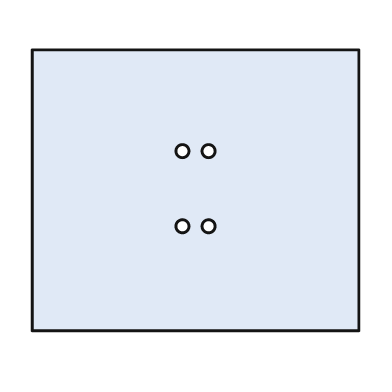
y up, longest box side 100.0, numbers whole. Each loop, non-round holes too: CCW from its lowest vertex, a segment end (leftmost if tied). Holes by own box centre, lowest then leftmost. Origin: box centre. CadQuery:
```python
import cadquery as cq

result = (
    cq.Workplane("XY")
    .moveTo(-50.0, -43.0)
    .lineTo(50.0, -43.0)
    .lineTo(50.0, 43.0)
    .lineTo(-50.0, 43.0)
    .close()
    .moveTo(-4.0, -11.0)
    .circle(2.0)
    .moveTo(4.0, -11.0)
    .circle(2.0)
    .moveTo(-4.0, 12.0)
    .circle(2.0)
    .moveTo(4.0, 12.0)
    .circle(2.0)
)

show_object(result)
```